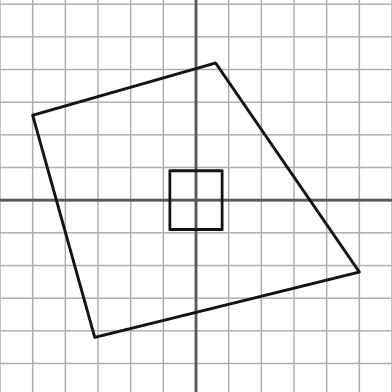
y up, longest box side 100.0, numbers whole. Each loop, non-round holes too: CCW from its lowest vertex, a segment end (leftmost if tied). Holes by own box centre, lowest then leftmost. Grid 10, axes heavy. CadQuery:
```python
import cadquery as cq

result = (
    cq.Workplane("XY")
    .moveTo(-31.0, -42.0)
    .lineTo(50.0, -22.0)
    .lineTo(6.0, 42.0)
    .lineTo(-50.0, 26.0)
    .close()
    .moveTo(-8.0, -9.0)
    .lineTo(8.0, -9.0)
    .lineTo(8.0, 9.0)
    .lineTo(-8.0, 9.0)
    .close()
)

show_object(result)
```